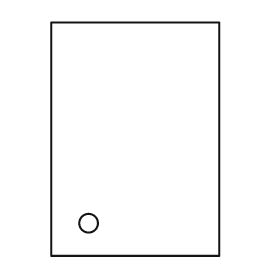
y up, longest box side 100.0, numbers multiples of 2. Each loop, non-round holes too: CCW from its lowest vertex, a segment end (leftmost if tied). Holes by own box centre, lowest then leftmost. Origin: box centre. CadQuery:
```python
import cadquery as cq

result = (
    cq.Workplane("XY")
    .moveTo(-36.0, -50.0)
    .lineTo(36.0, -50.0)
    .lineTo(36.0, 50.0)
    .lineTo(-36.0, 50.0)
    .close()
    .moveTo(-20.0, -36.0)
    .circle(4.0)
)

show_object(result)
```